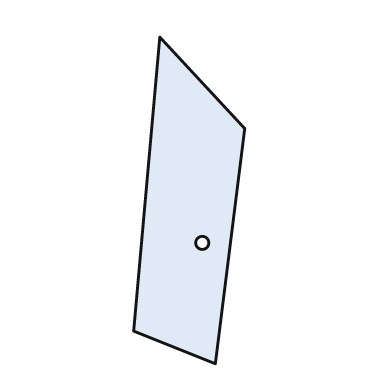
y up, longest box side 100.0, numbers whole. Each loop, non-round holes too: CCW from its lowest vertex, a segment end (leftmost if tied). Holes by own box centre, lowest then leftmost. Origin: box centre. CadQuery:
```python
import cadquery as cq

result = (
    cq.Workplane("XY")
    .moveTo(8.0, -50.0)
    .lineTo(17.0, 22.0)
    .lineTo(-9.0, 50.0)
    .lineTo(-17.0, -40.0)
    .close()
    .moveTo(4.0, -13.0)
    .circle(2.0)
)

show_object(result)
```